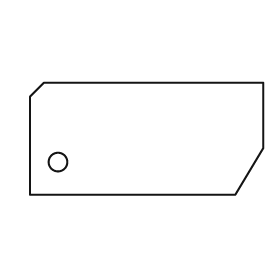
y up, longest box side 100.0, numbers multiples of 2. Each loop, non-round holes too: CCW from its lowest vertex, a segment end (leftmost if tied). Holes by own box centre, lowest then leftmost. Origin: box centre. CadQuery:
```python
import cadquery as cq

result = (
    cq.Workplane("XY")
    .moveTo(-50.0, -24.0)
    .lineTo(38.0, -24.0)
    .lineTo(50.0, -4.0)
    .lineTo(50.0, 24.0)
    .lineTo(-44.0, 24.0)
    .lineTo(-50.0, 18.0)
    .close()
    .moveTo(-38.0, -10.0)
    .circle(4.0)
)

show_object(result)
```